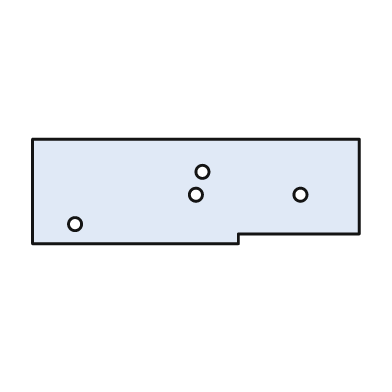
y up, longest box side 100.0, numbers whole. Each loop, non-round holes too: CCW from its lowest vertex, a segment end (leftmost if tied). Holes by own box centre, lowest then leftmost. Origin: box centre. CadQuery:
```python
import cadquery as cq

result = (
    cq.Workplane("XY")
    .moveTo(-50.0, -16.0)
    .lineTo(13.0, -16.0)
    .lineTo(13.0, -13.0)
    .lineTo(50.0, -13.0)
    .lineTo(50.0, 16.0)
    .lineTo(-50.0, 16.0)
    .close()
    .moveTo(-37.0, -10.0)
    .circle(2.0)
    .moveTo(0.0, -1.0)
    .circle(2.0)
    .moveTo(32.0, -1.0)
    .circle(2.0)
    .moveTo(2.0, 6.0)
    .circle(2.0)
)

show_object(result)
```